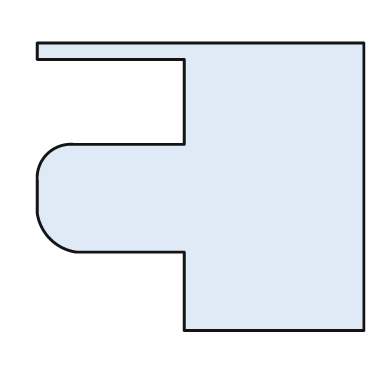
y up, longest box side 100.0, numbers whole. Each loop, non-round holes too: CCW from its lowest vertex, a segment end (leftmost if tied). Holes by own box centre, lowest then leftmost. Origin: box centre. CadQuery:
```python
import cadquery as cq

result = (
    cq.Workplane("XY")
    .moveTo(-5.0, -44.0)
    .lineTo(50.0, -44.0)
    .lineTo(50.0, 44.0)
    .lineTo(-50.0, 44.0)
    .lineTo(-50.0, 39.0)
    .lineTo(-5.0, 39.0)
    .lineTo(-5.0, 13.0)
    .lineTo(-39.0, 13.0)
    .threePointArc((-47.0, 10.0), (-50.0, 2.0))
    .lineTo(-50.0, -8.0)
    .threePointArc((-46.0, -16.0), (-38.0, -20.0))
    .lineTo(-5.0, -20.0)
    .close()
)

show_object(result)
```